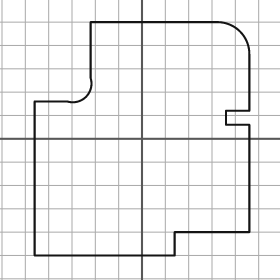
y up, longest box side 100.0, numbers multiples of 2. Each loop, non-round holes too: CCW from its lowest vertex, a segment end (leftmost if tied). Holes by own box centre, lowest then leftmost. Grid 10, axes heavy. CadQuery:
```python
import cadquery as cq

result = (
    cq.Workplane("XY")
    .moveTo(-46.0, -50.0)
    .lineTo(14.0, -50.0)
    .lineTo(14.0, -40.0)
    .lineTo(46.0, -40.0)
    .lineTo(46.0, 6.0)
    .lineTo(36.0, 6.0)
    .lineTo(36.0, 12.0)
    .lineTo(46.0, 12.0)
    .lineTo(46.0, 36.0)
    .threePointArc((42.0, 46.0), (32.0, 50.0))
    .lineTo(-22.0, 50.0)
    .lineTo(-22.0, 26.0)
    .threePointArc((-24.0, 18.0), (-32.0, 16.0))
    .lineTo(-46.0, 16.0)
    .close()
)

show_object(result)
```